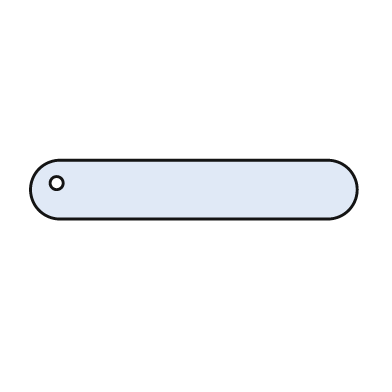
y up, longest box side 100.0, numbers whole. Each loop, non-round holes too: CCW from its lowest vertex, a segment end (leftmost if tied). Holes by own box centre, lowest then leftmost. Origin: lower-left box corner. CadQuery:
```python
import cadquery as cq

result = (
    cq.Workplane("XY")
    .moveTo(9.0, 0.0)
    .lineTo(91.0, 0.0)
    .threePointArc((100.0, 9.0), (91.0, 18.0))
    .lineTo(9.0, 18.0)
    .threePointArc((0.0, 9.0), (9.0, 0.0))
    .close()
    .moveTo(8.0, 11.0)
    .circle(2.0)
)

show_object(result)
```